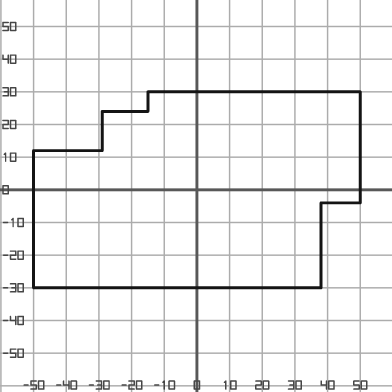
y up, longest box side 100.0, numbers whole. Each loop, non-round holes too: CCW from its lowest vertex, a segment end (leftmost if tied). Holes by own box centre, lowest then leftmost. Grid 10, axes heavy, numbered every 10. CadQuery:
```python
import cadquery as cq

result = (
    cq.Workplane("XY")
    .moveTo(-50.0, -30.0)
    .lineTo(38.0, -30.0)
    .lineTo(38.0, -4.0)
    .lineTo(50.0, -4.0)
    .lineTo(50.0, 30.0)
    .lineTo(-15.0, 30.0)
    .lineTo(-15.0, 24.0)
    .lineTo(-29.0, 24.0)
    .lineTo(-29.0, 12.0)
    .lineTo(-50.0, 12.0)
    .close()
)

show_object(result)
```